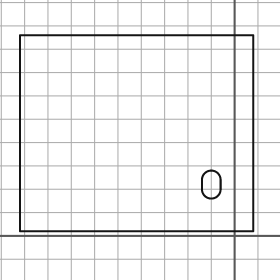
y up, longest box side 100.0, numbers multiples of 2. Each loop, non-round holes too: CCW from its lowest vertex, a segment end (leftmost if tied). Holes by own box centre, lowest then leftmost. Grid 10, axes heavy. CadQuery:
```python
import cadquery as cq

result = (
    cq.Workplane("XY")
    .moveTo(-92.0, 2.0)
    .lineTo(8.0, 2.0)
    .lineTo(8.0, 86.0)
    .lineTo(-92.0, 86.0)
    .close()
    .moveTo(-14.0, 20.0)
    .threePointArc((-10.0, 16.0), (-6.0, 20.0))
    .lineTo(-6.0, 24.0)
    .threePointArc((-10.0, 28.0), (-14.0, 24.0))
    .close()
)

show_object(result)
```